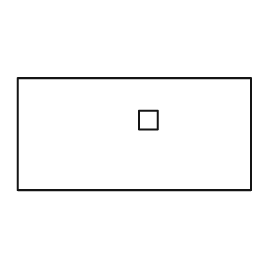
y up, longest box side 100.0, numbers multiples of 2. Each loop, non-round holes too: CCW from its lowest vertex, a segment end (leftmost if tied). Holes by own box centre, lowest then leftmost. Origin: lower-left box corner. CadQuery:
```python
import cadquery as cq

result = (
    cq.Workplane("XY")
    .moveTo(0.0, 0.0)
    .lineTo(100.0, 0.0)
    .lineTo(100.0, 48.0)
    .lineTo(0.0, 48.0)
    .close()
    .moveTo(52.0, 26.0)
    .lineTo(60.0, 26.0)
    .lineTo(60.0, 34.0)
    .lineTo(52.0, 34.0)
    .close()
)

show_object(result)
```